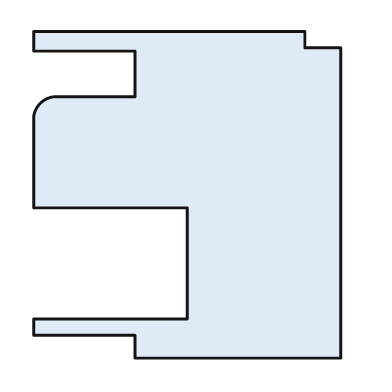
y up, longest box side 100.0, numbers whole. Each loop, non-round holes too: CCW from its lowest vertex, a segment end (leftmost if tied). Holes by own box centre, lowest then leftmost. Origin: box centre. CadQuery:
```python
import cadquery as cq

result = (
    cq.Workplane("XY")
    .moveTo(-16.0, -50.0)
    .lineTo(47.0, -50.0)
    .lineTo(47.0, 45.0)
    .lineTo(36.0, 45.0)
    .lineTo(36.0, 50.0)
    .lineTo(-47.0, 50.0)
    .lineTo(-47.0, 44.0)
    .lineTo(-16.0, 44.0)
    .lineTo(-16.0, 30.0)
    .lineTo(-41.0, 30.0)
    .threePointArc((-45.0, 28.0), (-47.0, 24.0))
    .lineTo(-47.0, -4.0)
    .lineTo(0.0, -4.0)
    .lineTo(0.0, -38.0)
    .lineTo(-47.0, -38.0)
    .lineTo(-47.0, -43.0)
    .lineTo(-16.0, -43.0)
    .close()
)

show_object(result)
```